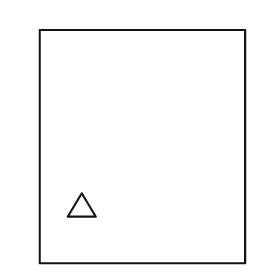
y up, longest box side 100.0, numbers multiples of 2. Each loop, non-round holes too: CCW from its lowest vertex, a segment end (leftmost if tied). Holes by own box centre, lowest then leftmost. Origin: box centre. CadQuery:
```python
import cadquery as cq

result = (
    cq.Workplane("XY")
    .moveTo(-44.0, -50.0)
    .lineTo(44.0, -50.0)
    .lineTo(44.0, 50.0)
    .lineTo(-44.0, 50.0)
    .close()
    .moveTo(-32.0, -30.0)
    .lineTo(-20.0, -30.0)
    .lineTo(-26.0, -20.0)
    .close()
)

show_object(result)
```